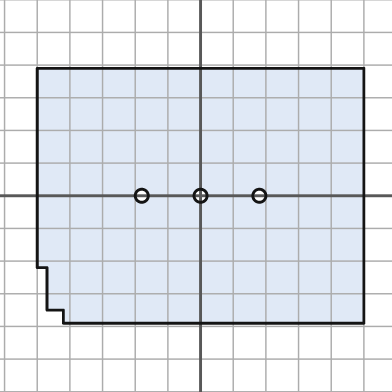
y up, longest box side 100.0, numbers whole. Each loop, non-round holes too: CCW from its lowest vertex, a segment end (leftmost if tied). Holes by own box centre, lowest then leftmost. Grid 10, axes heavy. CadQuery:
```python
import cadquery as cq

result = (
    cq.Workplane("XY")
    .moveTo(-42.0, -39.0)
    .lineTo(50.0, -39.0)
    .lineTo(50.0, 39.0)
    .lineTo(-50.0, 39.0)
    .lineTo(-50.0, -22.0)
    .lineTo(-47.0, -22.0)
    .lineTo(-47.0, -35.0)
    .lineTo(-42.0, -35.0)
    .close()
    .moveTo(-18.0, 0.0)
    .circle(2.0)
    .moveTo(0.0, 0.0)
    .circle(2.0)
    .moveTo(18.0, 0.0)
    .circle(2.0)
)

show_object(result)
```